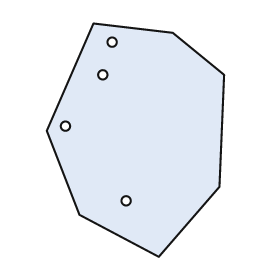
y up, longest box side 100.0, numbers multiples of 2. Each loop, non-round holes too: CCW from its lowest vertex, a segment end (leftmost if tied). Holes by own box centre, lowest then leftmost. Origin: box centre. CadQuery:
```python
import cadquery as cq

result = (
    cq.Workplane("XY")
    .moveTo(10.0, -50.0)
    .lineTo(36.0, -20.0)
    .lineTo(38.0, 28.0)
    .lineTo(16.0, 46.0)
    .lineTo(-18.0, 50.0)
    .lineTo(-38.0, 4.0)
    .lineTo(-24.0, -32.0)
    .close()
    .moveTo(-4.0, -26.0)
    .circle(2.0)
    .moveTo(-30.0, 6.0)
    .circle(2.0)
    .moveTo(-14.0, 28.0)
    .circle(2.0)
    .moveTo(-10.0, 42.0)
    .circle(2.0)
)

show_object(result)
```